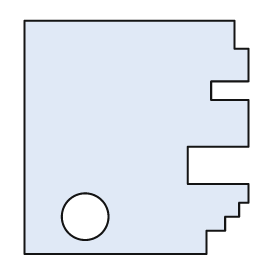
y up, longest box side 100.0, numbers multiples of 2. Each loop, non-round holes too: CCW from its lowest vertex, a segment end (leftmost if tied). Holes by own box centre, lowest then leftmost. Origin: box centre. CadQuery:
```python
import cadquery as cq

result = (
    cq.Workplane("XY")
    .moveTo(-48.0, -50.0)
    .lineTo(30.0, -50.0)
    .lineTo(30.0, -40.0)
    .lineTo(38.0, -40.0)
    .lineTo(38.0, -34.0)
    .lineTo(44.0, -34.0)
    .lineTo(44.0, -28.0)
    .lineTo(48.0, -28.0)
    .lineTo(48.0, -20.0)
    .lineTo(22.0, -20.0)
    .lineTo(22.0, -4.0)
    .lineTo(48.0, -4.0)
    .lineTo(48.0, 16.0)
    .lineTo(32.0, 16.0)
    .lineTo(32.0, 24.0)
    .lineTo(48.0, 24.0)
    .lineTo(48.0, 38.0)
    .lineTo(42.0, 38.0)
    .lineTo(42.0, 50.0)
    .lineTo(-48.0, 50.0)
    .close()
    .moveTo(-22.0, -34.0)
    .circle(10.0)
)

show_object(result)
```